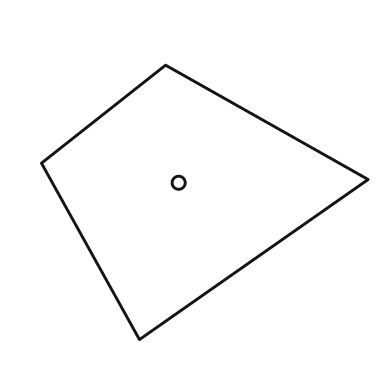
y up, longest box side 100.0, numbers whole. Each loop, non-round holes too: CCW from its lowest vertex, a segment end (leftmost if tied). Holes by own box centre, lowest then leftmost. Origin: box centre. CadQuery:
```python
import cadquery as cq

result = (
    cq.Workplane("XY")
    .moveTo(-20.0, -42.0)
    .lineTo(50.0, 7.0)
    .lineTo(-12.0, 42.0)
    .lineTo(-50.0, 12.0)
    .close()
    .moveTo(-8.0, 6.0)
    .circle(2.0)
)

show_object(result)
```